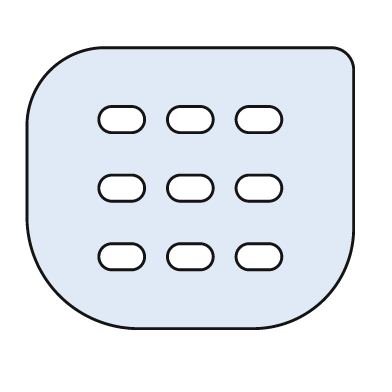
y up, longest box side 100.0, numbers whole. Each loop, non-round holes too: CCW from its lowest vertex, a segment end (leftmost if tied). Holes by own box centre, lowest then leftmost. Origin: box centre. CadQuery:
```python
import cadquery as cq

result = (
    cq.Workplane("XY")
    .moveTo(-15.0, -43.0)
    .lineTo(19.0, -43.0)
    .threePointArc((41.0, -34.0), (50.0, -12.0))
    .lineTo(50.0, 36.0)
    .threePointArc((48.0, 41.0), (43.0, 43.0))
    .lineTo(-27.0, 43.0)
    .threePointArc((-43.0, 36.0), (-50.0, 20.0))
    .lineTo(-50.0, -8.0)
    .threePointArc((-40.0, -33.0), (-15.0, -43.0))
    .close()
    .moveTo(-24.0, -25.0)
    .lineTo(-18.0, -25.0)
    .threePointArc((-14.0, -21.0), (-18.0, -17.0))
    .lineTo(-24.0, -17.0)
    .threePointArc((-28.0, -21.0), (-24.0, -25.0))
    .close()
    .moveTo(-3.0, -25.0)
    .lineTo(3.0, -25.0)
    .threePointArc((7.0, -21.0), (3.0, -17.0))
    .lineTo(-3.0, -17.0)
    .threePointArc((-7.0, -21.0), (-3.0, -25.0))
    .close()
    .moveTo(18.0, -25.0)
    .lineTo(24.0, -25.0)
    .threePointArc((28.0, -21.0), (24.0, -17.0))
    .lineTo(18.0, -17.0)
    .threePointArc((14.0, -21.0), (18.0, -25.0))
    .close()
    .moveTo(-24.0, -4.0)
    .lineTo(-18.0, -4.0)
    .threePointArc((-14.0, 0.0), (-18.0, 4.0))
    .lineTo(-24.0, 4.0)
    .threePointArc((-28.0, 0.0), (-24.0, -4.0))
    .close()
    .moveTo(-3.0, -4.0)
    .lineTo(3.0, -4.0)
    .threePointArc((7.0, 0.0), (3.0, 4.0))
    .lineTo(-3.0, 4.0)
    .threePointArc((-7.0, 0.0), (-3.0, -4.0))
    .close()
    .moveTo(18.0, -4.0)
    .lineTo(24.0, -4.0)
    .threePointArc((28.0, 0.0), (24.0, 4.0))
    .lineTo(18.0, 4.0)
    .threePointArc((14.0, 0.0), (18.0, -4.0))
    .close()
    .moveTo(-24.0, 17.0)
    .lineTo(-18.0, 17.0)
    .threePointArc((-14.0, 21.0), (-18.0, 25.0))
    .lineTo(-24.0, 25.0)
    .threePointArc((-28.0, 21.0), (-24.0, 17.0))
    .close()
    .moveTo(-3.0, 17.0)
    .lineTo(3.0, 17.0)
    .threePointArc((7.0, 21.0), (3.0, 25.0))
    .lineTo(-3.0, 25.0)
    .threePointArc((-7.0, 21.0), (-3.0, 17.0))
    .close()
    .moveTo(18.0, 17.0)
    .lineTo(24.0, 17.0)
    .threePointArc((28.0, 21.0), (24.0, 25.0))
    .lineTo(18.0, 25.0)
    .threePointArc((14.0, 21.0), (18.0, 17.0))
    .close()
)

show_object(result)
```